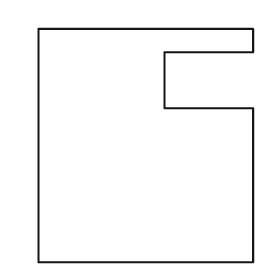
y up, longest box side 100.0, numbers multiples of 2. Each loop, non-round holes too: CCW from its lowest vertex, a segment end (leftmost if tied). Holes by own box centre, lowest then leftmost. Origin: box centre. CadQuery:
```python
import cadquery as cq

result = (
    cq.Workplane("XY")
    .moveTo(-46.0, -50.0)
    .lineTo(46.0, -50.0)
    .lineTo(46.0, 16.0)
    .lineTo(8.0, 16.0)
    .lineTo(8.0, 40.0)
    .lineTo(46.0, 40.0)
    .lineTo(46.0, 50.0)
    .lineTo(-46.0, 50.0)
    .close()
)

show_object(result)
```